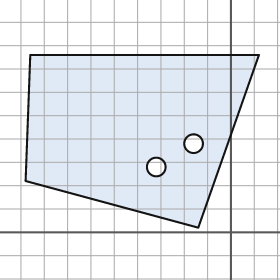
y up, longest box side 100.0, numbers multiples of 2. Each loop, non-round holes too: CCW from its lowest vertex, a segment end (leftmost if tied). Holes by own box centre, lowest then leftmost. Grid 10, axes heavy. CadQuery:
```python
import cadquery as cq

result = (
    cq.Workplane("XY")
    .moveTo(-14.0, 2.0)
    .lineTo(12.0, 76.0)
    .lineTo(-86.0, 76.0)
    .lineTo(-88.0, 22.0)
    .close()
    .moveTo(-32.0, 28.0)
    .circle(4.0)
    .moveTo(-16.0, 38.0)
    .circle(4.0)
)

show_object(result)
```